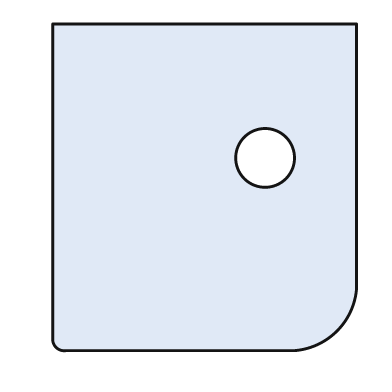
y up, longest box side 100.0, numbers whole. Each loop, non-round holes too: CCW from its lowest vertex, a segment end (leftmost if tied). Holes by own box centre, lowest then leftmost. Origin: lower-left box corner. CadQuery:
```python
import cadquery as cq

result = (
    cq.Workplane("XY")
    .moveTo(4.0, 0.0)
    .lineTo(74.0, 0.0)
    .threePointArc((87.0, 6.0), (93.0, 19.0))
    .lineTo(93.0, 100.0)
    .lineTo(0.0, 100.0)
    .lineTo(0.0, 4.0)
    .threePointArc((1.0, 1.0), (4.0, 0.0))
    .close()
    .moveTo(65.0, 59.0)
    .circle(9.0)
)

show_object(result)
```